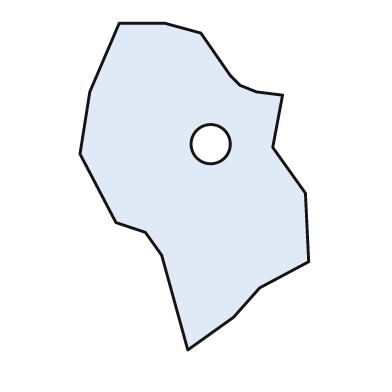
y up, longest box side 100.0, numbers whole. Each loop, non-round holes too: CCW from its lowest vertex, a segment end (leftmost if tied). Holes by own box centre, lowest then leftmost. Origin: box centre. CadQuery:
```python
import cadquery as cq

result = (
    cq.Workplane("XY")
    .moveTo(-2.0, -50.0)
    .lineTo(12.0, -40.0)
    .lineTo(20.0, -31.0)
    .lineTo(35.0, -23.0)
    .lineTo(34.0, -2.0)
    .lineTo(24.0, 12.0)
    .lineTo(27.0, 28.0)
    .lineTo(19.0, 29.0)
    .lineTo(14.0, 31.0)
    .lineTo(11.0, 34.0)
    .lineTo(2.0, 47.0)
    .lineTo(-9.0, 50.0)
    .lineTo(-23.0, 50.0)
    .lineTo(-32.0, 29.0)
    .lineTo(-35.0, 10.0)
    .lineTo(-24.0, -11.0)
    .lineTo(-15.0, -14.0)
    .lineTo(-10.0, -21.0)
    .close()
    .moveTo(5.0, 13.0)
    .circle(6.0)
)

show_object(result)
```